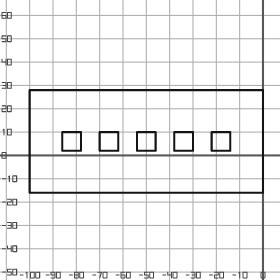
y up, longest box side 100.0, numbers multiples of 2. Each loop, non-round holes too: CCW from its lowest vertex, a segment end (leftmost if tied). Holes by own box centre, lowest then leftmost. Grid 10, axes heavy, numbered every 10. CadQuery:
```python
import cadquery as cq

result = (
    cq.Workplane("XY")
    .moveTo(-100.0, -16.0)
    .lineTo(0.0, -16.0)
    .lineTo(0.0, 28.0)
    .lineTo(-100.0, 28.0)
    .close()
    .moveTo(-86.0, 2.0)
    .lineTo(-78.0, 2.0)
    .lineTo(-78.0, 10.0)
    .lineTo(-86.0, 10.0)
    .close()
    .moveTo(-70.0, 2.0)
    .lineTo(-62.0, 2.0)
    .lineTo(-62.0, 10.0)
    .lineTo(-70.0, 10.0)
    .close()
    .moveTo(-54.0, 2.0)
    .lineTo(-46.0, 2.0)
    .lineTo(-46.0, 10.0)
    .lineTo(-54.0, 10.0)
    .close()
    .moveTo(-38.0, 2.0)
    .lineTo(-30.0, 2.0)
    .lineTo(-30.0, 10.0)
    .lineTo(-38.0, 10.0)
    .close()
    .moveTo(-22.0, 2.0)
    .lineTo(-14.0, 2.0)
    .lineTo(-14.0, 10.0)
    .lineTo(-22.0, 10.0)
    .close()
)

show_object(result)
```